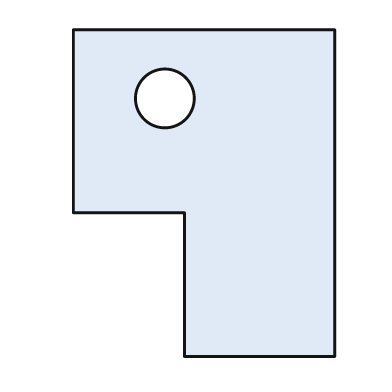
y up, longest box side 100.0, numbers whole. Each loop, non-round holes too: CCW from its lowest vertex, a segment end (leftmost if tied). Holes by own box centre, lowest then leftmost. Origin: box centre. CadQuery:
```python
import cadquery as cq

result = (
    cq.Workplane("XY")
    .moveTo(-6.0, -50.0)
    .lineTo(40.0, -50.0)
    .lineTo(40.0, 50.0)
    .lineTo(-40.0, 50.0)
    .lineTo(-40.0, -6.0)
    .lineTo(-6.0, -6.0)
    .close()
    .moveTo(-12.0, 29.0)
    .circle(9.0)
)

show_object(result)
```